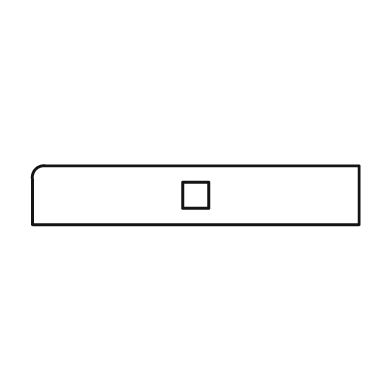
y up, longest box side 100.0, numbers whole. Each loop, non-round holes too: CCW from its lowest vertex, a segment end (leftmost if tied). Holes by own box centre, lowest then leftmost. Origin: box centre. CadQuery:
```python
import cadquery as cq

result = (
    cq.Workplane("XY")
    .moveTo(-50.0, -9.0)
    .lineTo(50.0, -9.0)
    .lineTo(50.0, 9.0)
    .lineTo(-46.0, 9.0)
    .threePointArc((-49.0, 8.0), (-50.0, 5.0))
    .close()
    .moveTo(-4.0, -4.0)
    .lineTo(4.0, -4.0)
    .lineTo(4.0, 4.0)
    .lineTo(-4.0, 4.0)
    .close()
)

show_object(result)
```